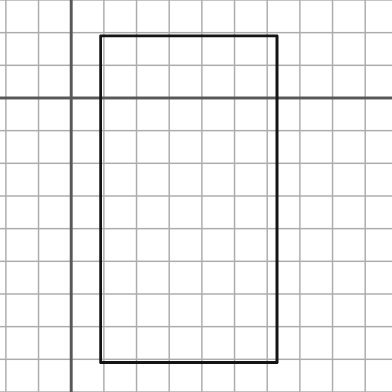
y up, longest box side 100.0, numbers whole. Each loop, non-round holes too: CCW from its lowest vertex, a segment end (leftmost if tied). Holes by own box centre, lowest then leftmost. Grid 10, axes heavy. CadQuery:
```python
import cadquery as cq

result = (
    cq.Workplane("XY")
    .moveTo(9.0, -81.0)
    .lineTo(63.0, -81.0)
    .lineTo(63.0, 19.0)
    .lineTo(9.0, 19.0)
    .close()
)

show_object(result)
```